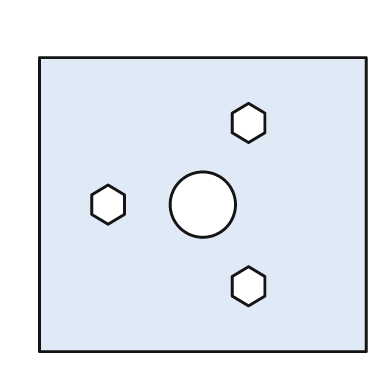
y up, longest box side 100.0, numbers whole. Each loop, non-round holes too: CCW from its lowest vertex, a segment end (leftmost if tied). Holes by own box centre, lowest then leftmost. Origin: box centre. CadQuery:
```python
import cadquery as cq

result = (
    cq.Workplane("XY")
    .moveTo(-50.0, -45.0)
    .lineTo(50.0, -45.0)
    .lineTo(50.0, 45.0)
    .lineTo(-50.0, 45.0)
    .close()
    .moveTo(14.0, -31.0)
    .lineTo(19.0, -28.0)
    .lineTo(19.0, -22.0)
    .lineTo(14.0, -19.0)
    .lineTo(9.0, -22.0)
    .lineTo(9.0, -28.0)
    .close()
    .moveTo(-29.0, -6.0)
    .lineTo(-24.0, -3.0)
    .lineTo(-24.0, 3.0)
    .lineTo(-29.0, 6.0)
    .lineTo(-34.0, 3.0)
    .lineTo(-34.0, -3.0)
    .close()
    .moveTo(0.0, 0.0)
    .circle(10.0)
    .moveTo(14.0, 19.0)
    .lineTo(19.0, 22.0)
    .lineTo(19.0, 28.0)
    .lineTo(14.0, 31.0)
    .lineTo(9.0, 28.0)
    .lineTo(9.0, 22.0)
    .close()
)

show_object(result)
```